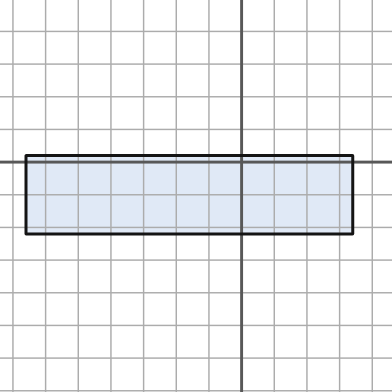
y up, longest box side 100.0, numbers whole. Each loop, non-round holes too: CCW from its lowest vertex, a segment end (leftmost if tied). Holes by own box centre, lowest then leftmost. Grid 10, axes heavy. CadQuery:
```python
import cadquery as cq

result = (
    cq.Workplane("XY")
    .moveTo(-66.0, -22.0)
    .lineTo(34.0, -22.0)
    .lineTo(34.0, 2.0)
    .lineTo(-66.0, 2.0)
    .close()
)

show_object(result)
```